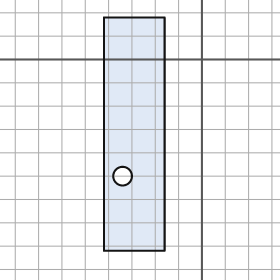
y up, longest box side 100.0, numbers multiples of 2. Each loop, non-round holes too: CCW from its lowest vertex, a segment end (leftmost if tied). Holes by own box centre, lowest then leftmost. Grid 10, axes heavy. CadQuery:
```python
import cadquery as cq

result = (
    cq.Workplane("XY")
    .moveTo(-42.0, -82.0)
    .lineTo(-16.0, -82.0)
    .lineTo(-16.0, 18.0)
    .lineTo(-42.0, 18.0)
    .close()
    .moveTo(-34.0, -50.0)
    .circle(4.0)
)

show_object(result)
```